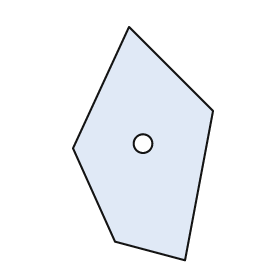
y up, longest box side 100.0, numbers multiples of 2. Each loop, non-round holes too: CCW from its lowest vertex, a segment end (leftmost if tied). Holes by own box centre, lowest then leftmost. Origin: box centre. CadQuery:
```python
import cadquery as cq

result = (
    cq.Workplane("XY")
    .moveTo(18.0, -50.0)
    .lineTo(30.0, 14.0)
    .lineTo(-6.0, 50.0)
    .lineTo(-30.0, -2.0)
    .lineTo(-12.0, -42.0)
    .close()
    .moveTo(0.0, 0.0)
    .circle(4.0)
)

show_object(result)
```